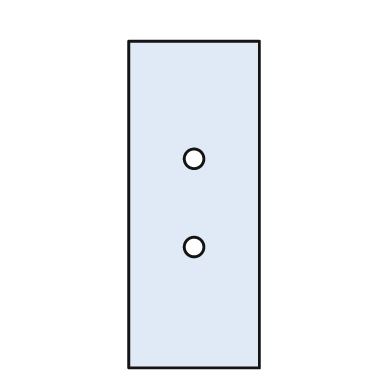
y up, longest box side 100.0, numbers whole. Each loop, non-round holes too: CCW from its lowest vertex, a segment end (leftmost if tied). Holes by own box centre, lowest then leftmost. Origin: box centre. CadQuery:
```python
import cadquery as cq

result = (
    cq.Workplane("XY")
    .moveTo(-20.0, -50.0)
    .lineTo(20.0, -50.0)
    .lineTo(20.0, 50.0)
    .lineTo(-20.0, 50.0)
    .close()
    .moveTo(0.0, -13.0)
    .circle(3.0)
    .moveTo(0.0, 14.0)
    .circle(3.0)
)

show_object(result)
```